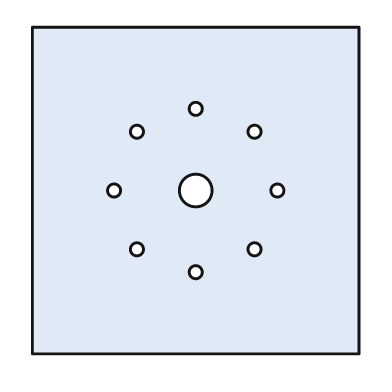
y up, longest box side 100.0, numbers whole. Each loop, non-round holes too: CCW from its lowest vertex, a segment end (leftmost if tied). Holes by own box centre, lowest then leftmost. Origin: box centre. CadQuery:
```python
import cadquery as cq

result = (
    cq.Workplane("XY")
    .moveTo(-50.0, -50.0)
    .lineTo(50.0, -50.0)
    .lineTo(50.0, 50.0)
    .lineTo(-50.0, 50.0)
    .close()
    .moveTo(0.0, -25.0)
    .circle(2.0)
    .moveTo(-18.0, -18.0)
    .circle(2.0)
    .moveTo(18.0, -18.0)
    .circle(2.0)
    .moveTo(-25.0, 0.0)
    .circle(2.0)
    .moveTo(0.0, 0.0)
    .circle(5.0)
    .moveTo(25.0, 0.0)
    .circle(2.0)
    .moveTo(-18.0, 18.0)
    .circle(2.0)
    .moveTo(18.0, 18.0)
    .circle(2.0)
    .moveTo(0.0, 25.0)
    .circle(2.0)
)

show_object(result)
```